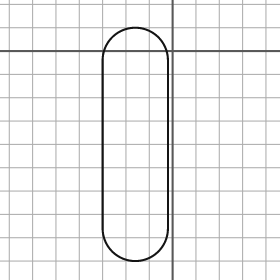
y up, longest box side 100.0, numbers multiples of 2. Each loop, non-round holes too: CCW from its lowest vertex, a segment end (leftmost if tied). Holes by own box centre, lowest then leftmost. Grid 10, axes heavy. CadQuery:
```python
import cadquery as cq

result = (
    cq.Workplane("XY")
    .moveTo(-30.0, -76.0)
    .threePointArc((-16.0, -90.0), (-2.0, -76.0))
    .lineTo(-2.0, -4.0)
    .threePointArc((-16.0, 10.0), (-30.0, -4.0))
    .close()
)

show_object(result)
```